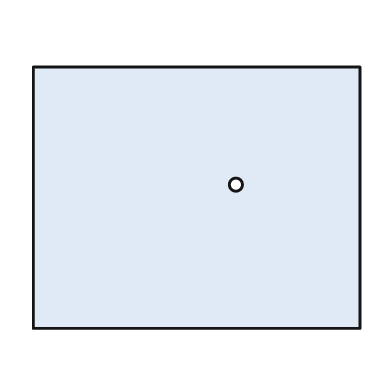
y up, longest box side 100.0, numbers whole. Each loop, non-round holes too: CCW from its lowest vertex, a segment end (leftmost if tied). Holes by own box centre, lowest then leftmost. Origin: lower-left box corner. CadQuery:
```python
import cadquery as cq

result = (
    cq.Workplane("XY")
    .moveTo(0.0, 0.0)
    .lineTo(100.0, 0.0)
    .lineTo(100.0, 80.0)
    .lineTo(0.0, 80.0)
    .close()
    .moveTo(62.0, 44.0)
    .circle(2.0)
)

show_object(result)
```